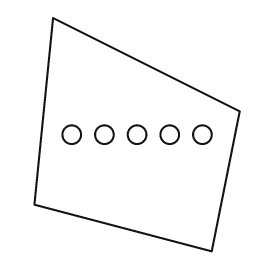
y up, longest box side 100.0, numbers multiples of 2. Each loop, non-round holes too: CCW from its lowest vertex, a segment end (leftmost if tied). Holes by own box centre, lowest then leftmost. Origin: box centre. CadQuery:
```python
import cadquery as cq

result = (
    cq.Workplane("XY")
    .moveTo(32.0, -50.0)
    .lineTo(44.0, 10.0)
    .lineTo(-36.0, 50.0)
    .lineTo(-44.0, -30.0)
    .close()
    .moveTo(-28.0, 0.0)
    .circle(4.0)
    .moveTo(-14.0, 0.0)
    .circle(4.0)
    .moveTo(0.0, 0.0)
    .circle(4.0)
    .moveTo(14.0, 0.0)
    .circle(4.0)
    .moveTo(28.0, 0.0)
    .circle(4.0)
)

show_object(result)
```